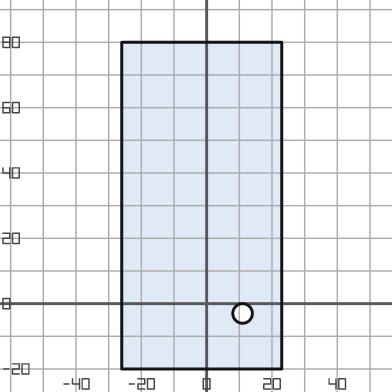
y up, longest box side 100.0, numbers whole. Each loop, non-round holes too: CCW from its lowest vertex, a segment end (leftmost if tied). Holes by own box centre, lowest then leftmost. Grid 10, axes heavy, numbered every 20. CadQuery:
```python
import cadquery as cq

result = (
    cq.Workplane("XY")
    .moveTo(-26.0, -20.0)
    .lineTo(23.0, -20.0)
    .lineTo(23.0, 80.0)
    .lineTo(-26.0, 80.0)
    .close()
    .moveTo(11.0, -3.0)
    .circle(3.0)
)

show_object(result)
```